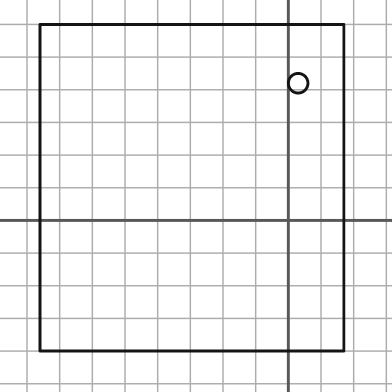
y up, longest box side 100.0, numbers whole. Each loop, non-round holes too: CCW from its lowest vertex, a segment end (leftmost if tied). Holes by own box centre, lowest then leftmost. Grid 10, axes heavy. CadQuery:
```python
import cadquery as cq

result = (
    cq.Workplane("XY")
    .moveTo(-76.0, -40.0)
    .lineTo(17.0, -40.0)
    .lineTo(17.0, 60.0)
    .lineTo(-76.0, 60.0)
    .close()
    .moveTo(3.0, 42.0)
    .circle(3.0)
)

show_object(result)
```